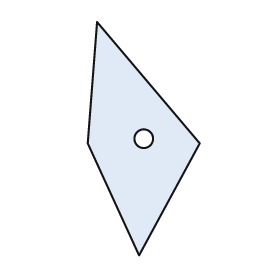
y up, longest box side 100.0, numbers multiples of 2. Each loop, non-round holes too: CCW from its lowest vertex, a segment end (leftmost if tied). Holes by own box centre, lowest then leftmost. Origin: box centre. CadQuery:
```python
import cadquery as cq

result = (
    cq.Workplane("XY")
    .moveTo(-2.0, -50.0)
    .lineTo(24.0, -2.0)
    .lineTo(-20.0, 50.0)
    .lineTo(-24.0, -2.0)
    .close()
    .moveTo(0.0, 0.0)
    .circle(4.0)
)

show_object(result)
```